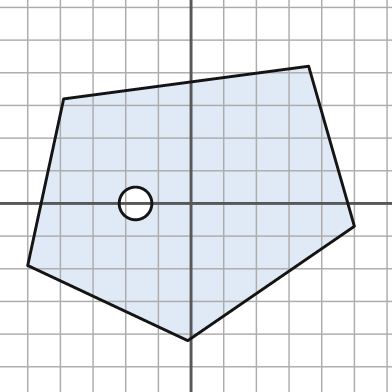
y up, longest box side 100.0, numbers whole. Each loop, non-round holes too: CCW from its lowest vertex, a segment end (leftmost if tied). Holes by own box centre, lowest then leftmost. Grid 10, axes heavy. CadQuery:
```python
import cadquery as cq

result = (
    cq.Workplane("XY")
    .moveTo(-1.0, -42.0)
    .lineTo(50.0, -7.0)
    .lineTo(36.0, 42.0)
    .lineTo(-39.0, 32.0)
    .lineTo(-50.0, -19.0)
    .close()
    .moveTo(-17.0, 0.0)
    .circle(5.0)
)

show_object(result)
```